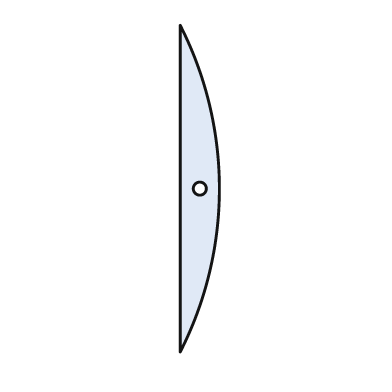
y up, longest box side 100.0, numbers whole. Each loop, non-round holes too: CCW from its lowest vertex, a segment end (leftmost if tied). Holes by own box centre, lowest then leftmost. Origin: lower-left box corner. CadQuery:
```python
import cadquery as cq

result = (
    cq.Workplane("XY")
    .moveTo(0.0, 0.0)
    .threePointArc((12.0, 50.0), (0.0, 100.0))
    .close()
    .moveTo(6.0, 50.0)
    .circle(2.0)
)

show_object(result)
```